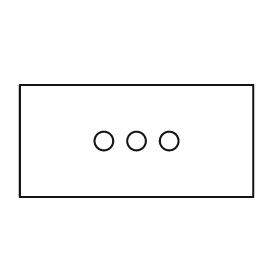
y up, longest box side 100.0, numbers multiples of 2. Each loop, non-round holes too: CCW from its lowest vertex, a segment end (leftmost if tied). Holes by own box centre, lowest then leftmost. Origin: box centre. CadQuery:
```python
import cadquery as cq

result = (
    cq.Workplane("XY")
    .moveTo(-50.0, -24.0)
    .lineTo(50.0, -24.0)
    .lineTo(50.0, 24.0)
    .lineTo(-50.0, 24.0)
    .close()
    .moveTo(-14.0, 0.0)
    .circle(4.0)
    .moveTo(0.0, 0.0)
    .circle(4.0)
    .moveTo(14.0, 0.0)
    .circle(4.0)
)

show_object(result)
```